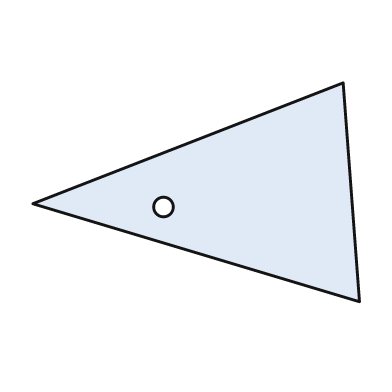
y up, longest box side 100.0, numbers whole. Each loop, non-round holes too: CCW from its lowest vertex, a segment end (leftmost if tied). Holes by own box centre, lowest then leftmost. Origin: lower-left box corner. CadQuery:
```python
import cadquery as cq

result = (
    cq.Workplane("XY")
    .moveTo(100.0, 0.0)
    .lineTo(95.0, 67.0)
    .lineTo(0.0, 30.0)
    .close()
    .moveTo(40.0, 29.0)
    .circle(3.0)
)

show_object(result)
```